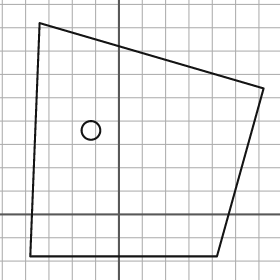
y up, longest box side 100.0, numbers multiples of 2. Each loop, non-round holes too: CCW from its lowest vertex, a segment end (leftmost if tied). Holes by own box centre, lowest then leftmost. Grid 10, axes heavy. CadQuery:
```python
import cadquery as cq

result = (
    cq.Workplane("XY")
    .moveTo(-38.0, -18.0)
    .lineTo(42.0, -18.0)
    .lineTo(62.0, 54.0)
    .lineTo(-34.0, 82.0)
    .close()
    .moveTo(-12.0, 36.0)
    .circle(4.0)
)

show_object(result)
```